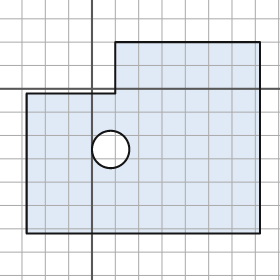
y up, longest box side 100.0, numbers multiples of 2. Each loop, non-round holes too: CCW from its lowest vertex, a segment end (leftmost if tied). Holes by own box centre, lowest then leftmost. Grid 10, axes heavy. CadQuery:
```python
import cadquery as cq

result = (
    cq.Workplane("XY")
    .moveTo(-28.0, -62.0)
    .lineTo(72.0, -62.0)
    .lineTo(72.0, 20.0)
    .lineTo(10.0, 20.0)
    .lineTo(10.0, -2.0)
    .lineTo(-28.0, -2.0)
    .close()
    .moveTo(8.0, -26.0)
    .circle(8.0)
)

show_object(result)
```